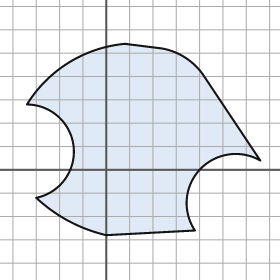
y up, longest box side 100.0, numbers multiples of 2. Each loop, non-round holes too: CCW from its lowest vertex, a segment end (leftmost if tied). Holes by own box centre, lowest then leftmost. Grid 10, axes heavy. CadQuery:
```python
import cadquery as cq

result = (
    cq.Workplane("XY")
    .moveTo(0.0, -28.0)
    .lineTo(38.0, -26.0)
    .threePointArc((40.0, 0.0), (66.0, 4.0))
    .lineTo(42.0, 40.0)
    .threePointArc((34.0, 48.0), (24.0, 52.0))
    .lineTo(8.0, 54.0)
    .threePointArc((-16.0, 46.0), (-34.0, 28.0))
    .threePointArc((-14.0, 10.0), (-30.0, -12.0))
    .threePointArc((-16.0, -22.0), (0.0, -28.0))
    .close()
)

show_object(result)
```